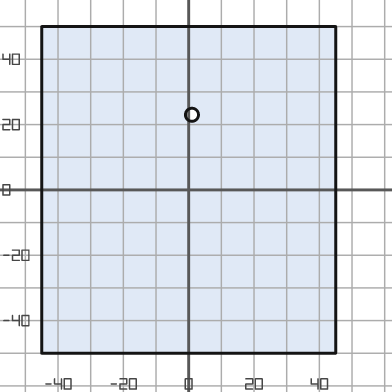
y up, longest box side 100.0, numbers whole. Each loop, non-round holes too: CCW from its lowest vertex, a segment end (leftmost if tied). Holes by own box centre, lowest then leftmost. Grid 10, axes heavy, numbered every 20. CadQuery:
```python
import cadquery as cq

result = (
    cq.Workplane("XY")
    .moveTo(-45.0, -50.0)
    .lineTo(45.0, -50.0)
    .lineTo(45.0, 50.0)
    .lineTo(-45.0, 50.0)
    .close()
    .moveTo(1.0, 23.0)
    .circle(2.0)
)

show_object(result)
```